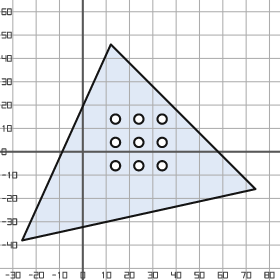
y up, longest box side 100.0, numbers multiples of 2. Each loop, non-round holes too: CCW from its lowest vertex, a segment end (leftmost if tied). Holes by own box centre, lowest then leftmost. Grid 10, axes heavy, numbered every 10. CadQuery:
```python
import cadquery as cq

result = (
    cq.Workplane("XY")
    .moveTo(-26.0, -38.0)
    .lineTo(74.0, -16.0)
    .lineTo(12.0, 46.0)
    .close()
    .moveTo(14.0, -6.0)
    .circle(2.0)
    .moveTo(24.0, -6.0)
    .circle(2.0)
    .moveTo(34.0, -6.0)
    .circle(2.0)
    .moveTo(14.0, 4.0)
    .circle(2.0)
    .moveTo(24.0, 4.0)
    .circle(2.0)
    .moveTo(34.0, 4.0)
    .circle(2.0)
    .moveTo(14.0, 14.0)
    .circle(2.0)
    .moveTo(24.0, 14.0)
    .circle(2.0)
    .moveTo(34.0, 14.0)
    .circle(2.0)
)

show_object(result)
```